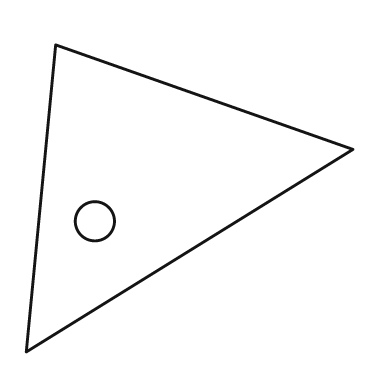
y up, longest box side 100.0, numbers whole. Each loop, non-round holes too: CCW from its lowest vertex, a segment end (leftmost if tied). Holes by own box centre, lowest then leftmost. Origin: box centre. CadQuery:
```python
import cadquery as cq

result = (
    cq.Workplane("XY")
    .moveTo(-50.0, -47.0)
    .lineTo(50.0, 15.0)
    .lineTo(-41.0, 47.0)
    .close()
    .moveTo(-29.0, -7.0)
    .circle(6.0)
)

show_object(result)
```